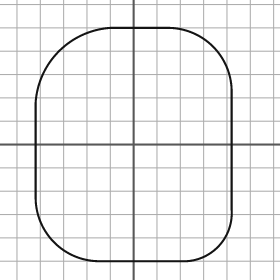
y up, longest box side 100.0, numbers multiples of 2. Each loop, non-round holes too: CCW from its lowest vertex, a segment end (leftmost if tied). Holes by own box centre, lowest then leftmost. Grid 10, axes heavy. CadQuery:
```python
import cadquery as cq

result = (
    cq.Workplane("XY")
    .moveTo(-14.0, -50.0)
    .lineTo(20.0, -50.0)
    .threePointArc((36.0, -44.0), (42.0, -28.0))
    .lineTo(42.0, 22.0)
    .threePointArc((34.0, 42.0), (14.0, 50.0))
    .lineTo(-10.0, 50.0)
    .threePointArc((-32.0, 40.0), (-42.0, 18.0))
    .lineTo(-42.0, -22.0)
    .threePointArc((-34.0, -42.0), (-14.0, -50.0))
    .close()
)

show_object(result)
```